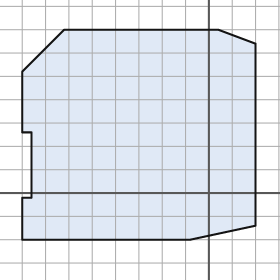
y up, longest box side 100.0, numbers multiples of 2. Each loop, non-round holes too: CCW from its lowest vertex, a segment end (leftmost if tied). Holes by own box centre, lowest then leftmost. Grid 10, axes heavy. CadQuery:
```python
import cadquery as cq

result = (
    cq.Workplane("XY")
    .moveTo(-80.0, -20.0)
    .lineTo(-8.0, -20.0)
    .lineTo(20.0, -14.0)
    .lineTo(20.0, 64.0)
    .lineTo(4.0, 70.0)
    .lineTo(-62.0, 70.0)
    .lineTo(-80.0, 52.0)
    .lineTo(-80.0, 26.0)
    .lineTo(-76.0, 26.0)
    .lineTo(-76.0, -2.0)
    .lineTo(-80.0, -2.0)
    .close()
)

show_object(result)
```